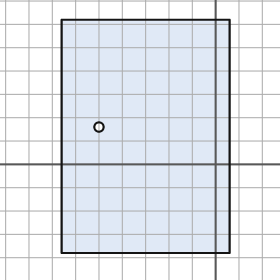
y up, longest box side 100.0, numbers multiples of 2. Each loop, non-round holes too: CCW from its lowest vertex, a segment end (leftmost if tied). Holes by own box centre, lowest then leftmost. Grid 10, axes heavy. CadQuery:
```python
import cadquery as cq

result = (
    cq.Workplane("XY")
    .moveTo(-66.0, -38.0)
    .lineTo(6.0, -38.0)
    .lineTo(6.0, 62.0)
    .lineTo(-66.0, 62.0)
    .close()
    .moveTo(-50.0, 16.0)
    .circle(2.0)
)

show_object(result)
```